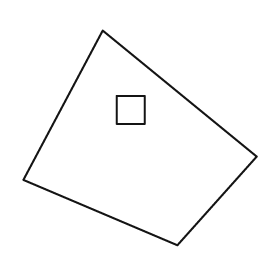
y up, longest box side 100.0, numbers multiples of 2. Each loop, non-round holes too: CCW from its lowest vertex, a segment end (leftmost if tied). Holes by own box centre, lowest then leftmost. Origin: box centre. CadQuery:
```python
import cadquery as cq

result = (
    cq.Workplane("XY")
    .moveTo(16.0, -46.0)
    .lineTo(50.0, -8.0)
    .lineTo(-16.0, 46.0)
    .lineTo(-50.0, -18.0)
    .close()
    .moveTo(-10.0, 6.0)
    .lineTo(2.0, 6.0)
    .lineTo(2.0, 18.0)
    .lineTo(-10.0, 18.0)
    .close()
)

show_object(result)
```